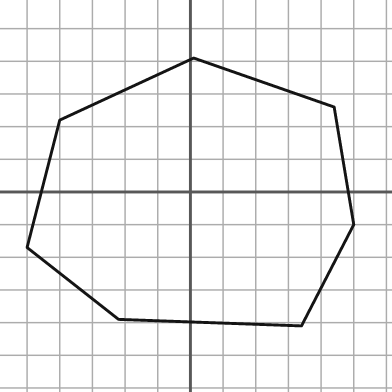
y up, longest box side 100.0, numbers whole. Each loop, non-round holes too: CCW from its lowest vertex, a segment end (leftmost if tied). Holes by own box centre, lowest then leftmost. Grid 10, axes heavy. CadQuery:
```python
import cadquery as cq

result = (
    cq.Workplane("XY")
    .moveTo(34.0, -41.0)
    .lineTo(50.0, -10.0)
    .lineTo(44.0, 26.0)
    .lineTo(1.0, 41.0)
    .lineTo(-40.0, 22.0)
    .lineTo(-50.0, -17.0)
    .lineTo(-22.0, -39.0)
    .close()
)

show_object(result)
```